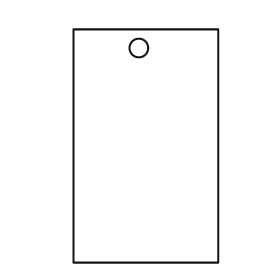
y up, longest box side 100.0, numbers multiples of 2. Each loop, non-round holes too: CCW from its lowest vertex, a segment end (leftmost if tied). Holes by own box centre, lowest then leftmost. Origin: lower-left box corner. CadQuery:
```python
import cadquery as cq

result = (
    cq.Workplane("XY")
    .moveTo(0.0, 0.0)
    .lineTo(62.0, 0.0)
    .lineTo(62.0, 100.0)
    .lineTo(0.0, 100.0)
    .close()
    .moveTo(28.0, 92.0)
    .circle(4.0)
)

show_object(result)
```